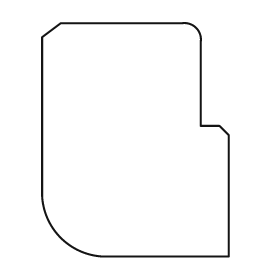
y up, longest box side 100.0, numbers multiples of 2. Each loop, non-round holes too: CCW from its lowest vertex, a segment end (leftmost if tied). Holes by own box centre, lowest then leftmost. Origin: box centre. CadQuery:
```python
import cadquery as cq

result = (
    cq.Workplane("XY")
    .moveTo(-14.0, -50.0)
    .lineTo(40.0, -50.0)
    .lineTo(40.0, 2.0)
    .lineTo(36.0, 6.0)
    .lineTo(28.0, 6.0)
    .lineTo(28.0, 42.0)
    .threePointArc((26.0, 48.0), (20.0, 50.0))
    .lineTo(-32.0, 50.0)
    .lineTo(-40.0, 44.0)
    .lineTo(-40.0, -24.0)
    .threePointArc((-32.0, -42.0), (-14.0, -50.0))
    .close()
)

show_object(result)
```